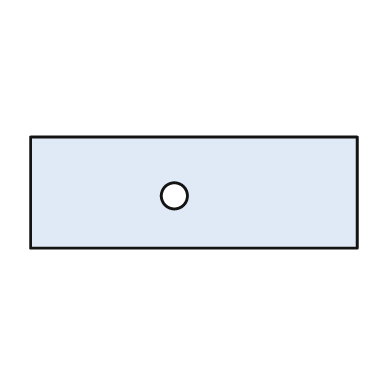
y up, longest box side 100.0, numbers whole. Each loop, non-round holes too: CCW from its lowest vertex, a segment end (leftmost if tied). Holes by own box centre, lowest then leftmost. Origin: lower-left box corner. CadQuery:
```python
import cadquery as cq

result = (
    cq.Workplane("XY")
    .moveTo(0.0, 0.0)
    .lineTo(100.0, 0.0)
    .lineTo(100.0, 34.0)
    .lineTo(0.0, 34.0)
    .close()
    .moveTo(44.0, 16.0)
    .circle(4.0)
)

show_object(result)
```